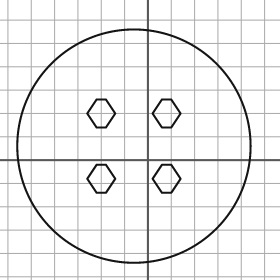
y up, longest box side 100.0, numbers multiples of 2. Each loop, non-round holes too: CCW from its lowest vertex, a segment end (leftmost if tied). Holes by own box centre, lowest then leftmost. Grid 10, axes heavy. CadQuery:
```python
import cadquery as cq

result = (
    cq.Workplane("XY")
    .moveTo(-6.0, 6.0)
    .circle(50.0)
    .moveTo(-22.0, -14.0)
    .lineTo(-18.0, -14.0)
    .lineTo(-14.0, -8.0)
    .lineTo(-18.0, -2.0)
    .lineTo(-22.0, -2.0)
    .lineTo(-26.0, -8.0)
    .close()
    .moveTo(6.0, -14.0)
    .lineTo(10.0, -14.0)
    .lineTo(14.0, -8.0)
    .lineTo(10.0, -2.0)
    .lineTo(6.0, -2.0)
    .lineTo(2.0, -8.0)
    .close()
    .moveTo(-22.0, 14.0)
    .lineTo(-18.0, 14.0)
    .lineTo(-14.0, 20.0)
    .lineTo(-18.0, 26.0)
    .lineTo(-22.0, 26.0)
    .lineTo(-26.0, 20.0)
    .close()
    .moveTo(6.0, 14.0)
    .lineTo(10.0, 14.0)
    .lineTo(14.0, 20.0)
    .lineTo(10.0, 26.0)
    .lineTo(6.0, 26.0)
    .lineTo(2.0, 20.0)
    .close()
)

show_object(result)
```